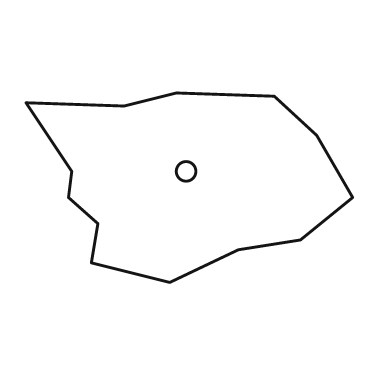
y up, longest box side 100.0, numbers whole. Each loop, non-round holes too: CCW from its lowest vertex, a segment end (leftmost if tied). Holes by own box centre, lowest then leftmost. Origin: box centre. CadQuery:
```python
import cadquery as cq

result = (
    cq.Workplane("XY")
    .moveTo(-6.0, -29.0)
    .lineTo(15.0, -19.0)
    .lineTo(34.0, -16.0)
    .lineTo(50.0, -3.0)
    .lineTo(39.0, 16.0)
    .lineTo(26.0, 28.0)
    .lineTo(-4.0, 29.0)
    .lineTo(-20.0, 25.0)
    .lineTo(-50.0, 26.0)
    .lineTo(-36.0, 5.0)
    .lineTo(-37.0, -3.0)
    .lineTo(-28.0, -11.0)
    .lineTo(-30.0, -23.0)
    .close()
    .moveTo(-1.0, 5.0)
    .circle(3.0)
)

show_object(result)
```